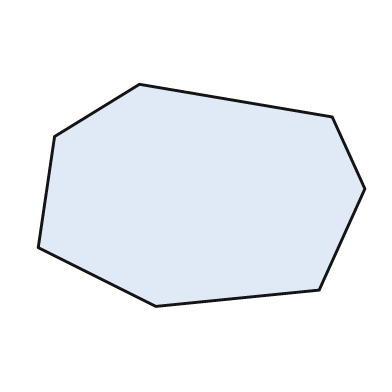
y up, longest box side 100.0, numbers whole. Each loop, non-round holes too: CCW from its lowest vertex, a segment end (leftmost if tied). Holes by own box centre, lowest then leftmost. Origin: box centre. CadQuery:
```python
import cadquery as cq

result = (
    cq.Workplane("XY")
    .moveTo(-14.0, -34.0)
    .lineTo(36.0, -29.0)
    .lineTo(50.0, 2.0)
    .lineTo(40.0, 24.0)
    .lineTo(-19.0, 34.0)
    .lineTo(-45.0, 18.0)
    .lineTo(-50.0, -16.0)
    .close()
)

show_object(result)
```